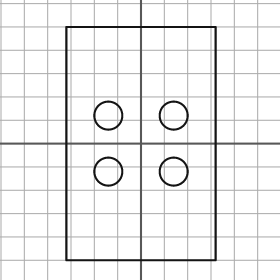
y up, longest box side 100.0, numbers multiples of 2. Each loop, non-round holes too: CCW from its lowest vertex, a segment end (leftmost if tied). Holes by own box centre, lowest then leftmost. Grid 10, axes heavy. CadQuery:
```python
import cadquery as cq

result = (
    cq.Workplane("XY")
    .moveTo(-32.0, -50.0)
    .lineTo(32.0, -50.0)
    .lineTo(32.0, 50.0)
    .lineTo(-32.0, 50.0)
    .close()
    .moveTo(-14.0, -12.0)
    .circle(6.0)
    .moveTo(14.0, -12.0)
    .circle(6.0)
    .moveTo(-14.0, 12.0)
    .circle(6.0)
    .moveTo(14.0, 12.0)
    .circle(6.0)
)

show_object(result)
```